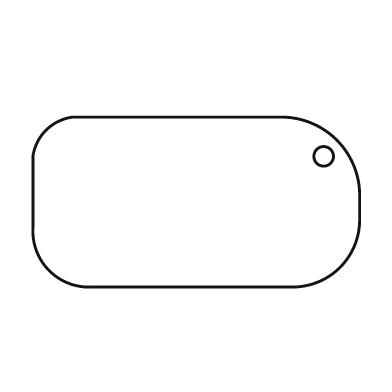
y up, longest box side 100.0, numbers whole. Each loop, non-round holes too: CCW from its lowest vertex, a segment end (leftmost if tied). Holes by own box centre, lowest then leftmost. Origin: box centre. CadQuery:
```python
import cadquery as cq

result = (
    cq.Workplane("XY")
    .moveTo(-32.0, -26.0)
    .lineTo(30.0, -26.0)
    .threePointArc((44.0, -20.0), (50.0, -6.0))
    .lineTo(50.0, 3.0)
    .threePointArc((43.0, 19.0), (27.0, 26.0))
    .lineTo(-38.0, 26.0)
    .threePointArc((-46.0, 22.0), (-50.0, 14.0))
    .lineTo(-50.0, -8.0)
    .threePointArc((-45.0, -21.0), (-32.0, -26.0))
    .close()
    .moveTo(39.0, 14.0)
    .circle(3.0)
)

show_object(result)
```